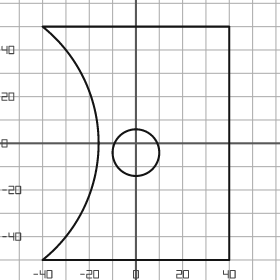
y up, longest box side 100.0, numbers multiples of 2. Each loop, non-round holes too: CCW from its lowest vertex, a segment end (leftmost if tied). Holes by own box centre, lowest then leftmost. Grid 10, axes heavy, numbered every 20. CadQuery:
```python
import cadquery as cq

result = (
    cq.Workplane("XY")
    .moveTo(-40.0, -50.0)
    .lineTo(40.0, -50.0)
    .lineTo(40.0, 50.0)
    .lineTo(-40.0, 50.0)
    .threePointArc((-16.0, 0.0), (-40.0, -50.0))
    .close()
    .moveTo(0.0, -4.0)
    .circle(10.0)
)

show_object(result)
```